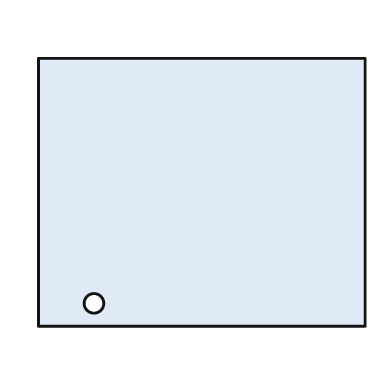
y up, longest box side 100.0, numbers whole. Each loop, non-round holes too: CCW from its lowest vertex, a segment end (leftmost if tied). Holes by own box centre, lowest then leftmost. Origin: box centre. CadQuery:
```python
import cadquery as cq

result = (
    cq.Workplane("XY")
    .moveTo(-50.0, -41.0)
    .lineTo(50.0, -41.0)
    .lineTo(50.0, 41.0)
    .lineTo(-50.0, 41.0)
    .close()
    .moveTo(-33.0, -34.0)
    .circle(3.0)
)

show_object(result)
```